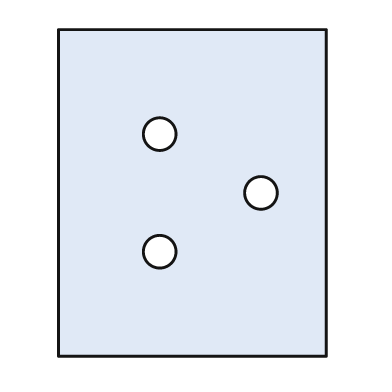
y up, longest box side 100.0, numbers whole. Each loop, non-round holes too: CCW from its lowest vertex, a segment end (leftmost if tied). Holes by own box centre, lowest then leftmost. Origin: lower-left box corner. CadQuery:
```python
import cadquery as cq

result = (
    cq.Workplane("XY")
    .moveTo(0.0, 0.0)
    .lineTo(82.0, 0.0)
    .lineTo(82.0, 100.0)
    .lineTo(0.0, 100.0)
    .close()
    .moveTo(31.0, 32.0)
    .circle(5.0)
    .moveTo(62.0, 50.0)
    .circle(5.0)
    .moveTo(31.0, 68.0)
    .circle(5.0)
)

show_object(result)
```